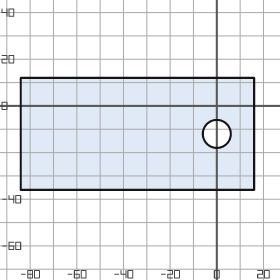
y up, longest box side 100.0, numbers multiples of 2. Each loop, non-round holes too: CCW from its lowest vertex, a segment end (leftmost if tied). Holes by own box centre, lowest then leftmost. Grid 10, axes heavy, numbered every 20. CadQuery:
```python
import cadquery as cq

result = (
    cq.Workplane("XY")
    .moveTo(-84.0, -36.0)
    .lineTo(16.0, -36.0)
    .lineTo(16.0, 12.0)
    .lineTo(-84.0, 12.0)
    .close()
    .moveTo(0.0, -12.0)
    .circle(6.0)
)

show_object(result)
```